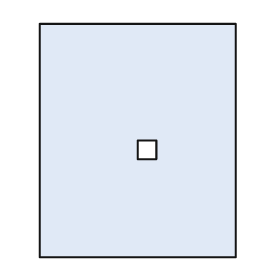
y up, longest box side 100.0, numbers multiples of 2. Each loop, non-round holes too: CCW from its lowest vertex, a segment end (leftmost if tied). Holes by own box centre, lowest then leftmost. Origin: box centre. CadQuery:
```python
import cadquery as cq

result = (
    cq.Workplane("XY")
    .moveTo(-42.0, -50.0)
    .lineTo(42.0, -50.0)
    .lineTo(42.0, 50.0)
    .lineTo(-42.0, 50.0)
    .close()
    .moveTo(0.0, -8.0)
    .lineTo(8.0, -8.0)
    .lineTo(8.0, 0.0)
    .lineTo(0.0, 0.0)
    .close()
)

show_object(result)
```